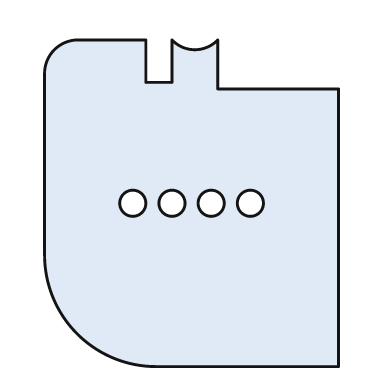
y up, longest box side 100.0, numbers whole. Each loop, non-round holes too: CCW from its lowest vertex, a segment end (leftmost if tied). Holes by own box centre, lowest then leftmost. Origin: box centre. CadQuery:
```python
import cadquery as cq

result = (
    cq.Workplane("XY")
    .moveTo(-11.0, -50.0)
    .lineTo(45.0, -50.0)
    .lineTo(45.0, 35.0)
    .lineTo(8.0, 35.0)
    .lineTo(8.0, 50.0)
    .threePointArc((1.0, 47.0), (-6.0, 50.0))
    .lineTo(-6.0, 37.0)
    .lineTo(-14.0, 37.0)
    .lineTo(-14.0, 50.0)
    .lineTo(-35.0, 50.0)
    .threePointArc((-42.0, 47.0), (-45.0, 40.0))
    .lineTo(-45.0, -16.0)
    .threePointArc((-35.0, -40.0), (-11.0, -50.0))
    .close()
    .moveTo(-18.0, 0.0)
    .circle(4.0)
    .moveTo(-6.0, 0.0)
    .circle(4.0)
    .moveTo(6.0, 0.0)
    .circle(4.0)
    .moveTo(18.0, 0.0)
    .circle(4.0)
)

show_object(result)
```